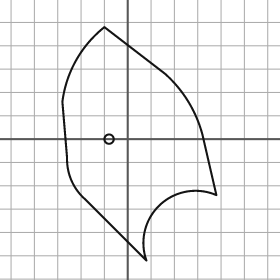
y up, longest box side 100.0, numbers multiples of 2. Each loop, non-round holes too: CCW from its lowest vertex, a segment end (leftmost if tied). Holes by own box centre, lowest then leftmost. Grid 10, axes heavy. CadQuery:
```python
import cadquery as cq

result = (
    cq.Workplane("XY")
    .moveTo(8.0, -52.0)
    .threePointArc((14.0, -28.0), (38.0, -24.0))
    .lineTo(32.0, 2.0)
    .threePointArc((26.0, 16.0), (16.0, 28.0))
    .lineTo(-10.0, 48.0)
    .threePointArc((-22.0, 34.0), (-28.0, 16.0))
    .lineTo(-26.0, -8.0)
    .threePointArc((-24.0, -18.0), (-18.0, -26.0))
    .close()
    .moveTo(-8.0, 0.0)
    .circle(2.0)
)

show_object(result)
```